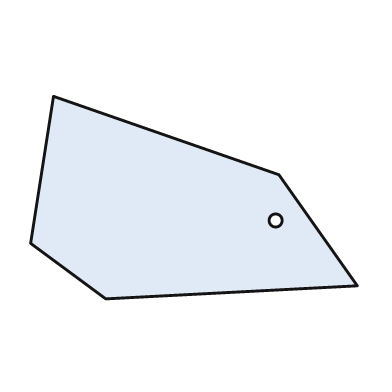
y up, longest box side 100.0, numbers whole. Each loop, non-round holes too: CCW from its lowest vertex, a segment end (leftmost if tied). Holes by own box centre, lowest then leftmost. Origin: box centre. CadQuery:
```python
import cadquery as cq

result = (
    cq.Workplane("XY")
    .moveTo(-27.0, -31.0)
    .lineTo(50.0, -27.0)
    .lineTo(26.0, 7.0)
    .lineTo(-43.0, 31.0)
    .lineTo(-50.0, -14.0)
    .close()
    .moveTo(25.0, -7.0)
    .circle(2.0)
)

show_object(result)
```